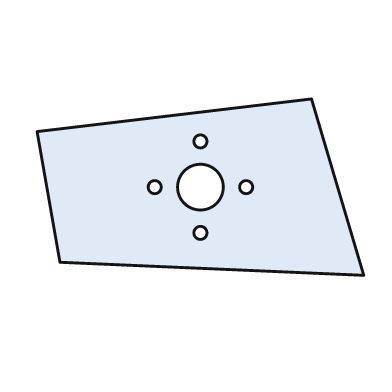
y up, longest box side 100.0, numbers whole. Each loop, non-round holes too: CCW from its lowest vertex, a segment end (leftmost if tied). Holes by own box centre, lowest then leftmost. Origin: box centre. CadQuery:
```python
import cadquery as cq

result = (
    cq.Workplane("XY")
    .moveTo(50.0, -27.0)
    .lineTo(34.0, 27.0)
    .lineTo(-50.0, 17.0)
    .lineTo(-43.0, -23.0)
    .close()
    .moveTo(0.0, -14.0)
    .circle(2.0)
    .moveTo(-14.0, 0.0)
    .circle(2.0)
    .moveTo(0.0, 0.0)
    .circle(7.0)
    .moveTo(14.0, 0.0)
    .circle(2.0)
    .moveTo(0.0, 14.0)
    .circle(2.0)
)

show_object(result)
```